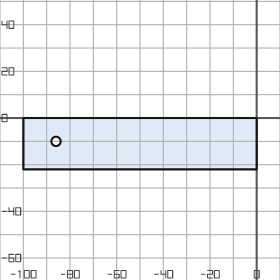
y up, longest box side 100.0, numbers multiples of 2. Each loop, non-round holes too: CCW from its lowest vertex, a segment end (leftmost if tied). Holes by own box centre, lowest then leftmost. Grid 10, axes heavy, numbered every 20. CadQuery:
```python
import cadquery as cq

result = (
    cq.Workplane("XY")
    .moveTo(-100.0, -22.0)
    .lineTo(0.0, -22.0)
    .lineTo(0.0, 0.0)
    .lineTo(-100.0, 0.0)
    .close()
    .moveTo(-86.0, -10.0)
    .circle(2.0)
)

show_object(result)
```